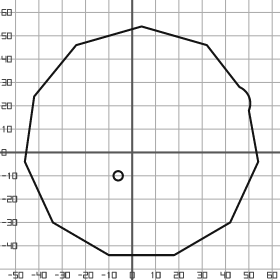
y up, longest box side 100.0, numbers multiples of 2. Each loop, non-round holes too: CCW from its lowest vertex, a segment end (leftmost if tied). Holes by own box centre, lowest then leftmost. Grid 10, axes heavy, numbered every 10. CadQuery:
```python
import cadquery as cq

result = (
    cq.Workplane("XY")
    .moveTo(-10.0, -44.0)
    .lineTo(18.0, -44.0)
    .lineTo(42.0, -30.0)
    .lineTo(54.0, -4.0)
    .lineTo(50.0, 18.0)
    .threePointArc((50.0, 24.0), (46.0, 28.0))
    .lineTo(32.0, 46.0)
    .lineTo(4.0, 54.0)
    .lineTo(-24.0, 46.0)
    .lineTo(-42.0, 24.0)
    .lineTo(-46.0, -4.0)
    .lineTo(-34.0, -30.0)
    .close()
    .moveTo(-6.0, -10.0)
    .circle(2.0)
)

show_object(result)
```